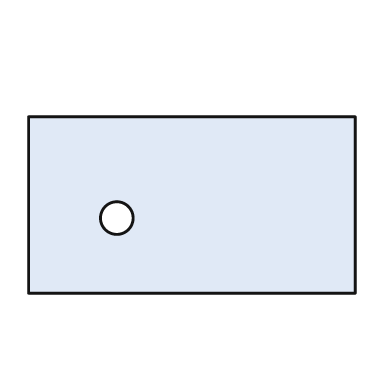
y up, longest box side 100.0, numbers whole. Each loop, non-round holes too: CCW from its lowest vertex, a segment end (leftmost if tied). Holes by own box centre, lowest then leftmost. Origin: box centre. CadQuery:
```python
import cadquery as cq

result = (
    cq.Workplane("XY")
    .moveTo(-50.0, -27.0)
    .lineTo(50.0, -27.0)
    .lineTo(50.0, 27.0)
    .lineTo(-50.0, 27.0)
    .close()
    .moveTo(-23.0, -4.0)
    .circle(5.0)
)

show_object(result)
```